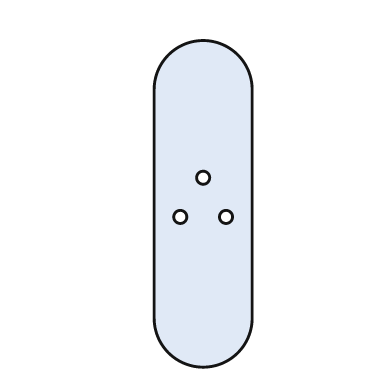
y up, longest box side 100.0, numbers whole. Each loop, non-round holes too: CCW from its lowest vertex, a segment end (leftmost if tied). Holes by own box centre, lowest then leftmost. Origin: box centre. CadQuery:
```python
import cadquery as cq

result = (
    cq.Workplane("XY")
    .moveTo(-15.0, -35.0)
    .threePointArc((0.0, -50.0), (15.0, -35.0))
    .lineTo(15.0, 35.0)
    .threePointArc((0.0, 50.0), (-15.0, 35.0))
    .close()
    .moveTo(-7.0, -4.0)
    .circle(2.0)
    .moveTo(7.0, -4.0)
    .circle(2.0)
    .moveTo(0.0, 8.0)
    .circle(2.0)
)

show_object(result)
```